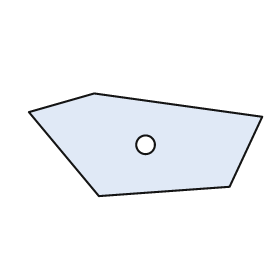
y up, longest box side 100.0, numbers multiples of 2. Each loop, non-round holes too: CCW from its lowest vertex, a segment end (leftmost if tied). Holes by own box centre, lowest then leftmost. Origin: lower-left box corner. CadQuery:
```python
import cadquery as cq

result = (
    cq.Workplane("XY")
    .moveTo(30.0, 0.0)
    .lineTo(86.0, 4.0)
    .lineTo(100.0, 34.0)
    .lineTo(28.0, 44.0)
    .lineTo(0.0, 36.0)
    .close()
    .moveTo(50.0, 22.0)
    .circle(4.0)
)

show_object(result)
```